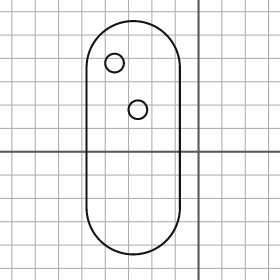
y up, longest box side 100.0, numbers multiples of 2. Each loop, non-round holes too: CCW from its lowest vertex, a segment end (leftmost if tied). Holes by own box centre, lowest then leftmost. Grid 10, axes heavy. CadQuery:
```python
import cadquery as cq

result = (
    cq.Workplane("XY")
    .moveTo(-48.0, -24.0)
    .threePointArc((-28.0, -44.0), (-8.0, -24.0))
    .lineTo(-8.0, 36.0)
    .threePointArc((-28.0, 56.0), (-48.0, 36.0))
    .close()
    .moveTo(-26.0, 18.0)
    .circle(4.0)
    .moveTo(-36.0, 38.0)
    .circle(4.0)
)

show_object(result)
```